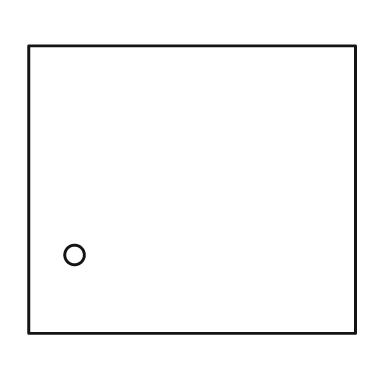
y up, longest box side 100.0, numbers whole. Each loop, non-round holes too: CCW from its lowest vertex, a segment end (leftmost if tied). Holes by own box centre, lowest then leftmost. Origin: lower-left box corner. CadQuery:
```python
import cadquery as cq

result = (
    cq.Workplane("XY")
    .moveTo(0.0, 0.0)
    .lineTo(100.0, 0.0)
    .lineTo(100.0, 88.0)
    .lineTo(0.0, 88.0)
    .close()
    .moveTo(14.0, 24.0)
    .circle(3.0)
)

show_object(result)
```